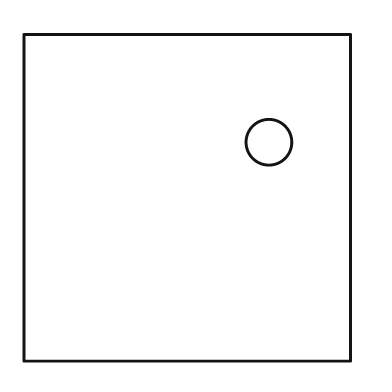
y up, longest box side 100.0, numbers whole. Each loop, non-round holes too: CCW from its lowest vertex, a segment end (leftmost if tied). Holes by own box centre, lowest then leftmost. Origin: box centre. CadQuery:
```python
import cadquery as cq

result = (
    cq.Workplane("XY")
    .moveTo(-50.0, -50.0)
    .lineTo(50.0, -50.0)
    .lineTo(50.0, 50.0)
    .lineTo(-50.0, 50.0)
    .close()
    .moveTo(25.0, 17.0)
    .circle(7.0)
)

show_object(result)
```